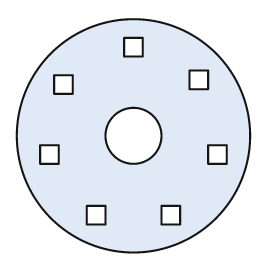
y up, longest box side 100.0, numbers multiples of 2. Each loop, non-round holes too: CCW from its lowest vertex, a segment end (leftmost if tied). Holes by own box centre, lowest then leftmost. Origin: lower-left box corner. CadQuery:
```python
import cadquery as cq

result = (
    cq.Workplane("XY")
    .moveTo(50.0, 50.0)
    .circle(50.0)
    .moveTo(30.0, 12.0)
    .lineTo(38.0, 12.0)
    .lineTo(38.0, 20.0)
    .lineTo(30.0, 20.0)
    .close()
    .moveTo(62.0, 12.0)
    .lineTo(70.0, 12.0)
    .lineTo(70.0, 20.0)
    .lineTo(62.0, 20.0)
    .close()
    .moveTo(10.0, 38.0)
    .lineTo(18.0, 38.0)
    .lineTo(18.0, 46.0)
    .lineTo(10.0, 46.0)
    .close()
    .moveTo(82.0, 38.0)
    .lineTo(90.0, 38.0)
    .lineTo(90.0, 46.0)
    .lineTo(82.0, 46.0)
    .close()
    .moveTo(50.0, 50.0)
    .circle(12.0)
    .moveTo(16.0, 68.0)
    .lineTo(24.0, 68.0)
    .lineTo(24.0, 76.0)
    .lineTo(16.0, 76.0)
    .close()
    .moveTo(74.0, 70.0)
    .lineTo(82.0, 70.0)
    .lineTo(82.0, 78.0)
    .lineTo(74.0, 78.0)
    .close()
    .moveTo(46.0, 84.0)
    .lineTo(54.0, 84.0)
    .lineTo(54.0, 92.0)
    .lineTo(46.0, 92.0)
    .close()
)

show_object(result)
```